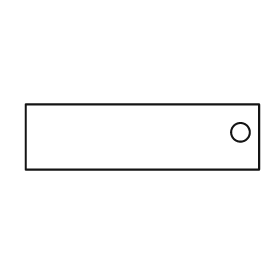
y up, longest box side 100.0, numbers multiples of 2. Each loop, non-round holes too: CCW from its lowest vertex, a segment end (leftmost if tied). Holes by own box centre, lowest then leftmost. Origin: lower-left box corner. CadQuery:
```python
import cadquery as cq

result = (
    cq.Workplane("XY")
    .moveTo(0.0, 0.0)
    .lineTo(100.0, 0.0)
    .lineTo(100.0, 28.0)
    .lineTo(0.0, 28.0)
    .close()
    .moveTo(92.0, 16.0)
    .circle(4.0)
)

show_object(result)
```